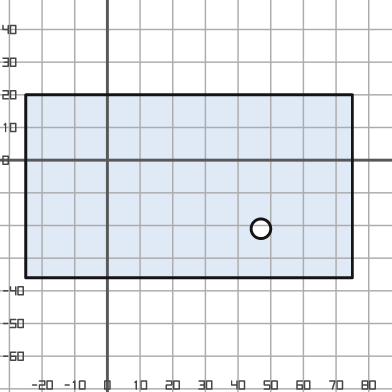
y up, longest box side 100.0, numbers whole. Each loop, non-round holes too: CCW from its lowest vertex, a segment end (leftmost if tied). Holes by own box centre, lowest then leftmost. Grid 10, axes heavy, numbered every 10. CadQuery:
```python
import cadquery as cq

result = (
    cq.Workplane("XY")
    .moveTo(-25.0, -36.0)
    .lineTo(75.0, -36.0)
    .lineTo(75.0, 20.0)
    .lineTo(-25.0, 20.0)
    .close()
    .moveTo(47.0, -21.0)
    .circle(3.0)
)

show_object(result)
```